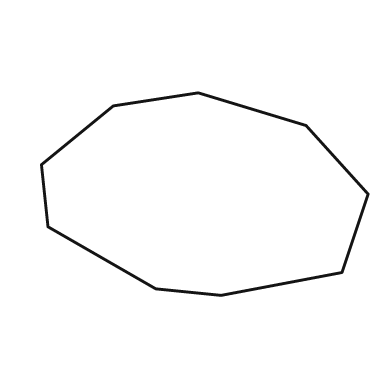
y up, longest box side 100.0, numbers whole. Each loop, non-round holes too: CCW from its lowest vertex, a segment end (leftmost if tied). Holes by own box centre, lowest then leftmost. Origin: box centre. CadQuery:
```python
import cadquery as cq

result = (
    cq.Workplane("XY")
    .moveTo(5.0, -31.0)
    .lineTo(42.0, -24.0)
    .lineTo(50.0, 0.0)
    .lineTo(31.0, 21.0)
    .lineTo(-2.0, 31.0)
    .lineTo(-28.0, 27.0)
    .lineTo(-50.0, 9.0)
    .lineTo(-48.0, -10.0)
    .lineTo(-15.0, -29.0)
    .close()
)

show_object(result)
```